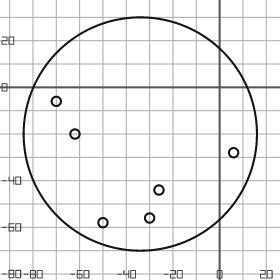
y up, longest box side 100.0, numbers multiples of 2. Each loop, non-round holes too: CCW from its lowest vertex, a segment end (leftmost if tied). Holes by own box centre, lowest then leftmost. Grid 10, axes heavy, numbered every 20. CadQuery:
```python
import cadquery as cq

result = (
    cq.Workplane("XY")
    .moveTo(-34.0, -20.0)
    .circle(50.0)
    .moveTo(-50.0, -58.0)
    .circle(2.0)
    .moveTo(-30.0, -56.0)
    .circle(2.0)
    .moveTo(-26.0, -44.0)
    .circle(2.0)
    .moveTo(6.0, -28.0)
    .circle(2.0)
    .moveTo(-62.0, -20.0)
    .circle(2.0)
    .moveTo(-70.0, -6.0)
    .circle(2.0)
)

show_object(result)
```